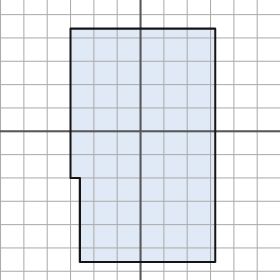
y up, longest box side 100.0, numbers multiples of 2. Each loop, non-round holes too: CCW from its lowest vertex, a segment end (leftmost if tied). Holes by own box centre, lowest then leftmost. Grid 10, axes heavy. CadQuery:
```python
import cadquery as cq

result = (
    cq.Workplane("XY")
    .moveTo(-26.0, -56.0)
    .lineTo(32.0, -56.0)
    .lineTo(32.0, 44.0)
    .lineTo(-30.0, 44.0)
    .lineTo(-30.0, -20.0)
    .lineTo(-26.0, -20.0)
    .close()
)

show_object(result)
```